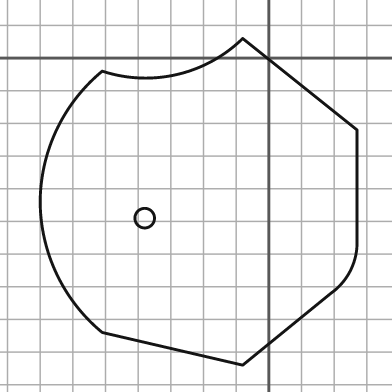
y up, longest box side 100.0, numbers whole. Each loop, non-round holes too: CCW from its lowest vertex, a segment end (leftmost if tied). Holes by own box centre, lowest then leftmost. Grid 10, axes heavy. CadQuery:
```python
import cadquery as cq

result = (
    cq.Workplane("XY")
    .moveTo(-8.0, -94.0)
    .lineTo(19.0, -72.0)
    .threePointArc((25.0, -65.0), (27.0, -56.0))
    .lineTo(27.0, -22.0)
    .lineTo(-8.0, 6.0)
    .threePointArc((-28.0, -5.0), (-51.0, -4.0))
    .threePointArc((-65.0, -22.0), (-70.0, -44.0))
    .threePointArc((-65.0, -66.0), (-51.0, -84.0))
    .close()
    .moveTo(-38.0, -49.0)
    .circle(3.0)
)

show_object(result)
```